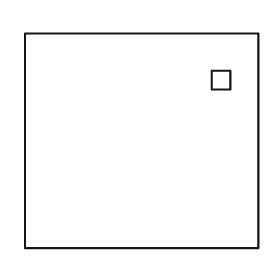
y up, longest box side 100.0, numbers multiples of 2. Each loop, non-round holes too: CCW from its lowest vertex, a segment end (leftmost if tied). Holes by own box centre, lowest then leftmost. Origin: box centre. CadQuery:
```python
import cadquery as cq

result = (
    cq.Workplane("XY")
    .moveTo(-50.0, -46.0)
    .lineTo(50.0, -46.0)
    .lineTo(50.0, 46.0)
    .lineTo(-50.0, 46.0)
    .close()
    .moveTo(30.0, 22.0)
    .lineTo(38.0, 22.0)
    .lineTo(38.0, 30.0)
    .lineTo(30.0, 30.0)
    .close()
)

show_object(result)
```